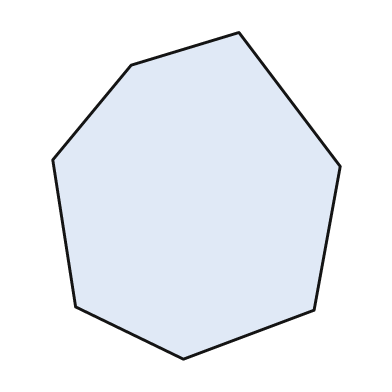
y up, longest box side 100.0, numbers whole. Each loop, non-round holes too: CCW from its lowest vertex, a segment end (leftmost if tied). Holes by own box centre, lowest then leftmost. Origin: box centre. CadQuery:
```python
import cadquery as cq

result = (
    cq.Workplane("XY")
    .moveTo(-4.0, -50.0)
    .lineTo(36.0, -35.0)
    .lineTo(44.0, 9.0)
    .lineTo(13.0, 50.0)
    .lineTo(-20.0, 40.0)
    .lineTo(-44.0, 11.0)
    .lineTo(-37.0, -34.0)
    .close()
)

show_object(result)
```